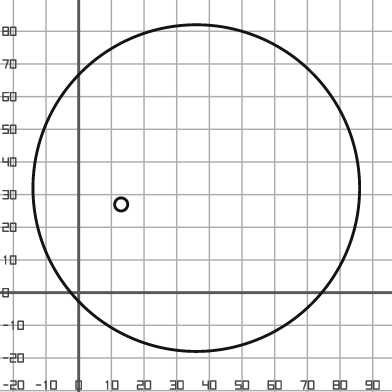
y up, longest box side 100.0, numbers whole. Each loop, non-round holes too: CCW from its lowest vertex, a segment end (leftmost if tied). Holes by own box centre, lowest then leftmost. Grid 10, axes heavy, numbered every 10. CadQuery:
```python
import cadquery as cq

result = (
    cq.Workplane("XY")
    .moveTo(36.0, 32.0)
    .circle(50.0)
    .moveTo(13.0, 27.0)
    .circle(2.0)
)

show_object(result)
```